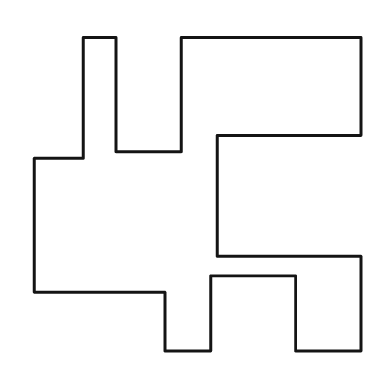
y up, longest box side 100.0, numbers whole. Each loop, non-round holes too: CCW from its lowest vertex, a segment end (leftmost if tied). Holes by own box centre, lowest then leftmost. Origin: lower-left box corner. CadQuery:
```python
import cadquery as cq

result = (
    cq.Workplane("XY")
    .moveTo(40.0, 0.0)
    .lineTo(54.0, 0.0)
    .lineTo(54.0, 23.0)
    .lineTo(80.0, 23.0)
    .lineTo(80.0, 0.0)
    .lineTo(100.0, 0.0)
    .lineTo(100.0, 29.0)
    .lineTo(56.0, 29.0)
    .lineTo(56.0, 66.0)
    .lineTo(100.0, 66.0)
    .lineTo(100.0, 96.0)
    .lineTo(45.0, 96.0)
    .lineTo(45.0, 61.0)
    .lineTo(25.0, 61.0)
    .lineTo(25.0, 96.0)
    .lineTo(15.0, 96.0)
    .lineTo(15.0, 59.0)
    .lineTo(0.0, 59.0)
    .lineTo(0.0, 18.0)
    .lineTo(40.0, 18.0)
    .close()
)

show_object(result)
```